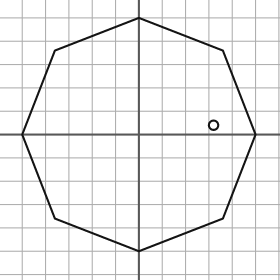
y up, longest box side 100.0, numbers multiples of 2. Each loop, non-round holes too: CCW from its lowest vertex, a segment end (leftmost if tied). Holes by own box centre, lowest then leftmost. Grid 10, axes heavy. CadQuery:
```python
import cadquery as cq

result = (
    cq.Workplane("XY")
    .moveTo(0.0, -50.0)
    .lineTo(36.0, -36.0)
    .lineTo(50.0, 0.0)
    .lineTo(36.0, 36.0)
    .lineTo(0.0, 50.0)
    .lineTo(-36.0, 36.0)
    .lineTo(-50.0, 0.0)
    .lineTo(-36.0, -36.0)
    .close()
    .moveTo(32.0, 4.0)
    .circle(2.0)
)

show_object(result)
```